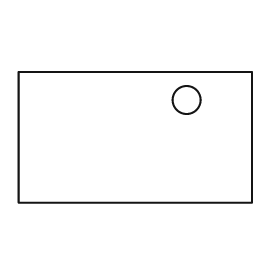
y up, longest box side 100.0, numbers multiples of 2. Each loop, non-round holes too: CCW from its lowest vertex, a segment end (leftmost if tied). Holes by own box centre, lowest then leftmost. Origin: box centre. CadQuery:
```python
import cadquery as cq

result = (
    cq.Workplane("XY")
    .moveTo(-50.0, -28.0)
    .lineTo(50.0, -28.0)
    .lineTo(50.0, 28.0)
    .lineTo(-50.0, 28.0)
    .close()
    .moveTo(22.0, 16.0)
    .circle(6.0)
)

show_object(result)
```